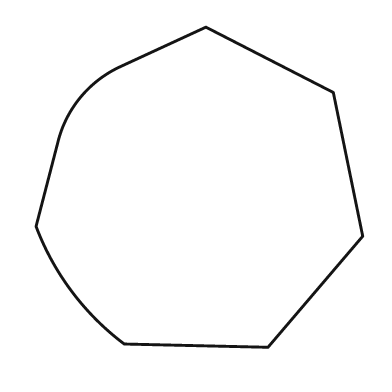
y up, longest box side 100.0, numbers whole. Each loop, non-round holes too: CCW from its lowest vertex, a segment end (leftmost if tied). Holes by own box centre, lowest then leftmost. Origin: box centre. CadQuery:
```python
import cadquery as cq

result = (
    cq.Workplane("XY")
    .moveTo(21.0, -49.0)
    .lineTo(50.0, -15.0)
    .lineTo(41.0, 29.0)
    .lineTo(2.0, 49.0)
    .lineTo(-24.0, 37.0)
    .threePointArc((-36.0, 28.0), (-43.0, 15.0))
    .lineTo(-50.0, -12.0)
    .threePointArc((-39.0, -32.0), (-23.0, -48.0))
    .close()
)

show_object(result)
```